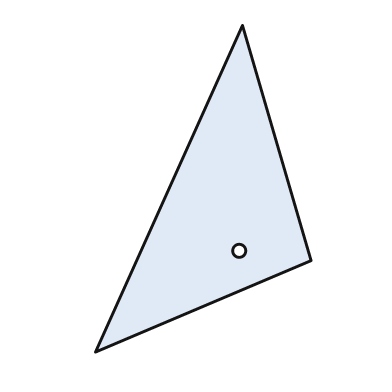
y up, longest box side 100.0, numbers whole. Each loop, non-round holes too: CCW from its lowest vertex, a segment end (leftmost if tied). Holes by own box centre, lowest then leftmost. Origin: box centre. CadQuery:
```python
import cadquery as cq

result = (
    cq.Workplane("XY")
    .moveTo(-33.0, -50.0)
    .lineTo(33.0, -22.0)
    .lineTo(12.0, 50.0)
    .close()
    .moveTo(11.0, -19.0)
    .circle(2.0)
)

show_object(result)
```